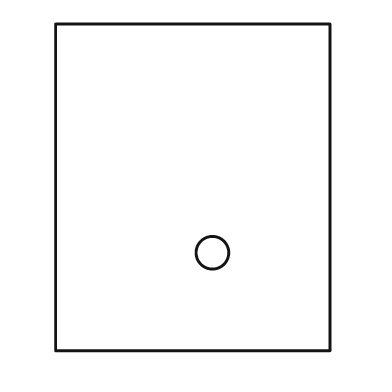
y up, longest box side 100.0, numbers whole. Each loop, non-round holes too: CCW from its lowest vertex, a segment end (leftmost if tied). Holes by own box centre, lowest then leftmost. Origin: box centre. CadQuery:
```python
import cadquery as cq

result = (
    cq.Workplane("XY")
    .moveTo(-42.0, -50.0)
    .lineTo(42.0, -50.0)
    .lineTo(42.0, 50.0)
    .lineTo(-42.0, 50.0)
    .close()
    .moveTo(6.0, -20.0)
    .circle(5.0)
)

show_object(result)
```